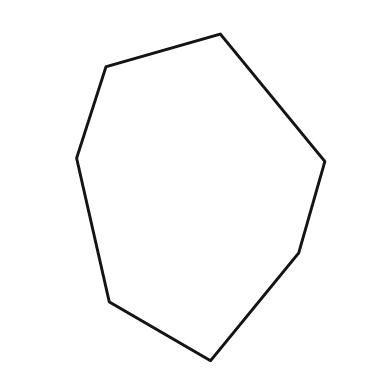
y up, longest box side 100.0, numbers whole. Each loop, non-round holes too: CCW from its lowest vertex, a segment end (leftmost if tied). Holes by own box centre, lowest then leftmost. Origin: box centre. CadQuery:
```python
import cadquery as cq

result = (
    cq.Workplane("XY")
    .moveTo(3.0, -50.0)
    .lineTo(30.0, -17.0)
    .lineTo(38.0, 11.0)
    .lineTo(6.0, 50.0)
    .lineTo(-29.0, 40.0)
    .lineTo(-38.0, 12.0)
    .lineTo(-28.0, -32.0)
    .close()
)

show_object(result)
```